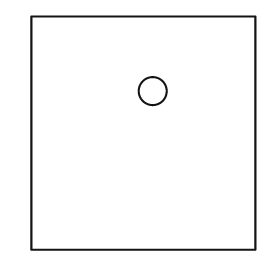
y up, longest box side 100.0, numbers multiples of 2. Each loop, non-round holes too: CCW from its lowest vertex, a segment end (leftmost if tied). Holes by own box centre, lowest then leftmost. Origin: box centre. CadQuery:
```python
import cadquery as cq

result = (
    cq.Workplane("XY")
    .moveTo(-48.0, -50.0)
    .lineTo(48.0, -50.0)
    .lineTo(48.0, 50.0)
    .lineTo(-48.0, 50.0)
    .close()
    .moveTo(4.0, 18.0)
    .circle(6.0)
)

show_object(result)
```